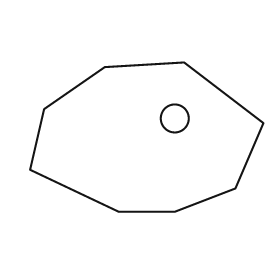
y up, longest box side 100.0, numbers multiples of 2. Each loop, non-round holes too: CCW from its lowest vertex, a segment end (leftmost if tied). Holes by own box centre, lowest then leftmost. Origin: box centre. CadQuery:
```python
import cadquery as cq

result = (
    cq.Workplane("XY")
    .moveTo(-12.0, -32.0)
    .lineTo(12.0, -32.0)
    .lineTo(38.0, -22.0)
    .lineTo(50.0, 6.0)
    .lineTo(16.0, 32.0)
    .lineTo(-18.0, 30.0)
    .lineTo(-44.0, 12.0)
    .lineTo(-50.0, -14.0)
    .close()
    .moveTo(12.0, 8.0)
    .circle(6.0)
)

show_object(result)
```